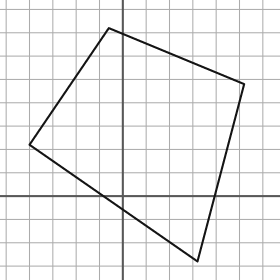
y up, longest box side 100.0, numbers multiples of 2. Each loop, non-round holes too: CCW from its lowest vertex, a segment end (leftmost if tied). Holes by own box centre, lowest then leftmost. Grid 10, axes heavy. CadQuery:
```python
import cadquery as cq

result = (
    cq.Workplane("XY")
    .moveTo(32.0, -28.0)
    .lineTo(52.0, 48.0)
    .lineTo(-6.0, 72.0)
    .lineTo(-40.0, 22.0)
    .close()
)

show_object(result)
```